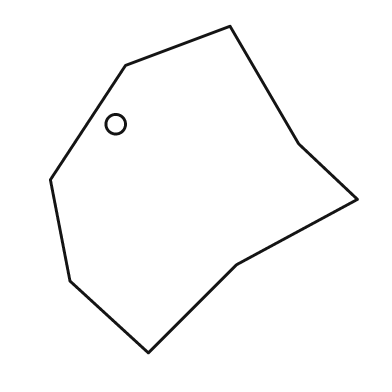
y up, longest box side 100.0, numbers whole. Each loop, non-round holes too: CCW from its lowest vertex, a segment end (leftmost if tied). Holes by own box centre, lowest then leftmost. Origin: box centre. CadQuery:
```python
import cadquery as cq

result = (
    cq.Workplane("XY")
    .moveTo(-17.0, -50.0)
    .lineTo(10.0, -23.0)
    .lineTo(47.0, -3.0)
    .lineTo(29.0, 14.0)
    .lineTo(8.0, 50.0)
    .lineTo(-24.0, 38.0)
    .lineTo(-47.0, 3.0)
    .lineTo(-41.0, -28.0)
    .close()
    .moveTo(-27.0, 20.0)
    .circle(3.0)
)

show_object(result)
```